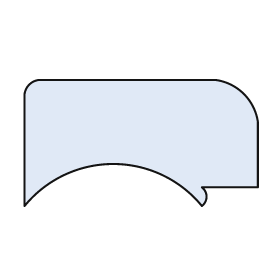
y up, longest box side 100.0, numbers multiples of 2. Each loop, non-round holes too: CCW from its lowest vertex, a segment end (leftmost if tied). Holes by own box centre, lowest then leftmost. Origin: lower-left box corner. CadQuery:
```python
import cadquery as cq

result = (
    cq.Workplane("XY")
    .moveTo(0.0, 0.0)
    .threePointArc((38.0, 18.0), (76.0, 0.0))
    .threePointArc((78.0, 4.0), (76.0, 8.0))
    .lineTo(100.0, 8.0)
    .lineTo(100.0, 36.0)
    .threePointArc((94.0, 48.0), (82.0, 54.0))
    .lineTo(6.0, 54.0)
    .threePointArc((2.0, 52.0), (0.0, 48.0))
    .close()
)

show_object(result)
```